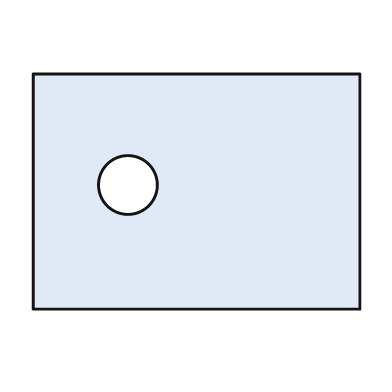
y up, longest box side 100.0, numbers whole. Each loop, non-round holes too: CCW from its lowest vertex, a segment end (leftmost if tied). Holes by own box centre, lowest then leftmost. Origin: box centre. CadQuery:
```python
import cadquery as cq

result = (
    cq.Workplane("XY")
    .moveTo(-50.0, -36.0)
    .lineTo(50.0, -36.0)
    .lineTo(50.0, 36.0)
    .lineTo(-50.0, 36.0)
    .close()
    .moveTo(-21.0, 2.0)
    .circle(9.0)
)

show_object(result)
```